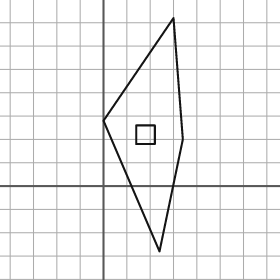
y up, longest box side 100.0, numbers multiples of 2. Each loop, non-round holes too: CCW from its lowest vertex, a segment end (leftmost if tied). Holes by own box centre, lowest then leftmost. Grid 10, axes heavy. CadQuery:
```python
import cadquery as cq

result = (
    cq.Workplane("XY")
    .moveTo(24.0, -28.0)
    .lineTo(34.0, 20.0)
    .lineTo(30.0, 72.0)
    .lineTo(0.0, 28.0)
    .close()
    .moveTo(14.0, 18.0)
    .lineTo(22.0, 18.0)
    .lineTo(22.0, 26.0)
    .lineTo(14.0, 26.0)
    .close()
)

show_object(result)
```